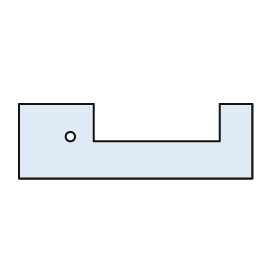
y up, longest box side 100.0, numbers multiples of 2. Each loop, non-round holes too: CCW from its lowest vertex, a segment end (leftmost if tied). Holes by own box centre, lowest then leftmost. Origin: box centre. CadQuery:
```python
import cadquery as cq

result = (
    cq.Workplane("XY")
    .moveTo(-50.0, -16.0)
    .lineTo(50.0, -16.0)
    .lineTo(50.0, 16.0)
    .lineTo(36.0, 16.0)
    .lineTo(36.0, 0.0)
    .lineTo(-18.0, 0.0)
    .lineTo(-18.0, 16.0)
    .lineTo(-50.0, 16.0)
    .close()
    .moveTo(-28.0, 2.0)
    .circle(2.0)
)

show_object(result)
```